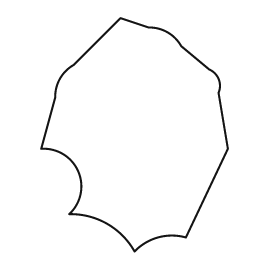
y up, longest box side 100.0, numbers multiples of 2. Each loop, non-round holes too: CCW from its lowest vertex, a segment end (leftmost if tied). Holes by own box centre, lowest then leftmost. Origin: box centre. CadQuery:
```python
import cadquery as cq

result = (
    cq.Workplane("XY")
    .moveTo(0.0, -50.0)
    .threePointArc((10.0, -44.0), (22.0, -44.0))
    .lineTo(40.0, -6.0)
    .lineTo(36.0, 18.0)
    .threePointArc((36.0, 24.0), (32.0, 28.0))
    .lineTo(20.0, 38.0)
    .threePointArc((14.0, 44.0), (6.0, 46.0))
    .lineTo(-6.0, 50.0)
    .lineTo(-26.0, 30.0)
    .threePointArc((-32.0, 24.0), (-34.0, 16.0))
    .lineTo(-40.0, -6.0)
    .threePointArc((-24.0, -16.0), (-28.0, -34.0))
    .threePointArc((-12.0, -38.0), (0.0, -50.0))
    .close()
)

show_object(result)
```